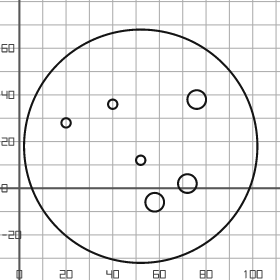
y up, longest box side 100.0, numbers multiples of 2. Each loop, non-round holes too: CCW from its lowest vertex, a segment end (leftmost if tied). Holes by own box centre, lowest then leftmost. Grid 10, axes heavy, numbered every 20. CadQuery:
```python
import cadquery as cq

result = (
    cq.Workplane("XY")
    .moveTo(52.0, 18.0)
    .circle(50.0)
    .moveTo(58.0, -6.0)
    .circle(4.0)
    .moveTo(72.0, 2.0)
    .circle(4.0)
    .moveTo(52.0, 12.0)
    .circle(2.0)
    .moveTo(20.0, 28.0)
    .circle(2.0)
    .moveTo(40.0, 36.0)
    .circle(2.0)
    .moveTo(76.0, 38.0)
    .circle(4.0)
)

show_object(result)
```